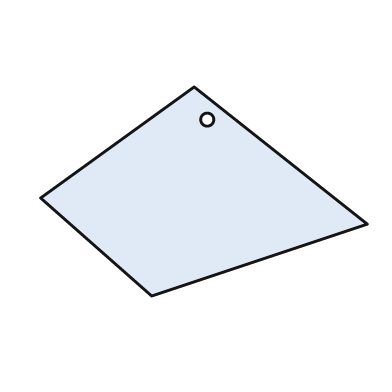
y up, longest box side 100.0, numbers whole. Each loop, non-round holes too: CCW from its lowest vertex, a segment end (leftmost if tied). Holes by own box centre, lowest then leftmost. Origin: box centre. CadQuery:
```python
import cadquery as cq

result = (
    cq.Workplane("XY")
    .moveTo(-16.0, -32.0)
    .lineTo(50.0, -10.0)
    .lineTo(-3.0, 32.0)
    .lineTo(-50.0, -2.0)
    .close()
    .moveTo(1.0, 22.0)
    .circle(2.0)
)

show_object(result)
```